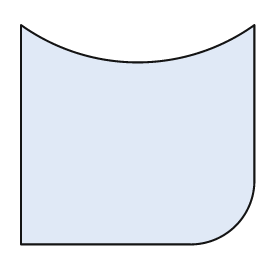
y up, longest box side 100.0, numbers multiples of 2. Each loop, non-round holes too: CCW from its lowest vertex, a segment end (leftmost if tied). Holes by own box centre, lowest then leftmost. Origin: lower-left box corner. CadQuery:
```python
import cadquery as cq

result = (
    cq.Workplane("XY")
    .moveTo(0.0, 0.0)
    .lineTo(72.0, 0.0)
    .threePointArc((92.0, 8.0), (100.0, 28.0))
    .lineTo(100.0, 94.0)
    .threePointArc((50.0, 78.0), (0.0, 94.0))
    .close()
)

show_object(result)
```